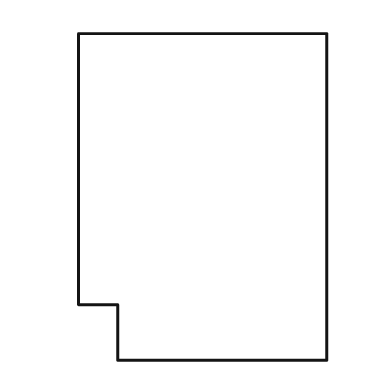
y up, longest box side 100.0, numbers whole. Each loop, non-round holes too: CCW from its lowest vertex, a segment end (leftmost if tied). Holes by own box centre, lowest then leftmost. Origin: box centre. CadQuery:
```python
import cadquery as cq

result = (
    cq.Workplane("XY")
    .moveTo(-26.0, -50.0)
    .lineTo(38.0, -50.0)
    .lineTo(38.0, 50.0)
    .lineTo(-38.0, 50.0)
    .lineTo(-38.0, -33.0)
    .lineTo(-26.0, -33.0)
    .close()
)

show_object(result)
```